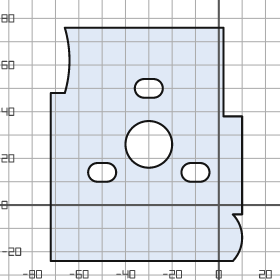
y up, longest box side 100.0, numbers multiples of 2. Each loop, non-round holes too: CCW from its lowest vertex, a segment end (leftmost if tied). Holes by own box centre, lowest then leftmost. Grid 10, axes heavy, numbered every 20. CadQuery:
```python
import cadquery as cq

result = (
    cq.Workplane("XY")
    .moveTo(-72.0, -24.0)
    .lineTo(6.0, -24.0)
    .threePointArc((10.0, -14.0), (6.0, -4.0))
    .lineTo(10.0, -4.0)
    .lineTo(10.0, 38.0)
    .lineTo(2.0, 38.0)
    .lineTo(2.0, 76.0)
    .lineTo(-66.0, 76.0)
    .threePointArc((-64.0, 62.0), (-66.0, 48.0))
    .lineTo(-72.0, 48.0)
    .close()
    .moveTo(-52.0, 10.0)
    .lineTo(-48.0, 10.0)
    .threePointArc((-44.0, 14.0), (-48.0, 18.0))
    .lineTo(-52.0, 18.0)
    .threePointArc((-56.0, 14.0), (-52.0, 10.0))
    .close()
    .moveTo(-12.0, 10.0)
    .lineTo(-8.0, 10.0)
    .threePointArc((-4.0, 14.0), (-8.0, 18.0))
    .lineTo(-12.0, 18.0)
    .threePointArc((-16.0, 14.0), (-12.0, 10.0))
    .close()
    .moveTo(-30.0, 26.0)
    .circle(10.0)
    .moveTo(-32.0, 46.0)
    .lineTo(-28.0, 46.0)
    .threePointArc((-24.0, 50.0), (-28.0, 54.0))
    .lineTo(-32.0, 54.0)
    .threePointArc((-36.0, 50.0), (-32.0, 46.0))
    .close()
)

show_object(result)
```